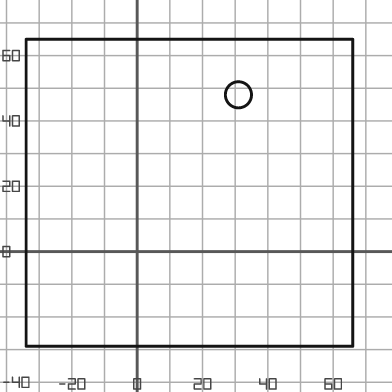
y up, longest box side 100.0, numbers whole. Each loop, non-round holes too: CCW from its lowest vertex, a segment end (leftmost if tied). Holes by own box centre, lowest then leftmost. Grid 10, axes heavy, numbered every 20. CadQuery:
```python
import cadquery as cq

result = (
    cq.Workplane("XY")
    .moveTo(-34.0, -29.0)
    .lineTo(66.0, -29.0)
    .lineTo(66.0, 65.0)
    .lineTo(-34.0, 65.0)
    .close()
    .moveTo(31.0, 48.0)
    .circle(4.0)
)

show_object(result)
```